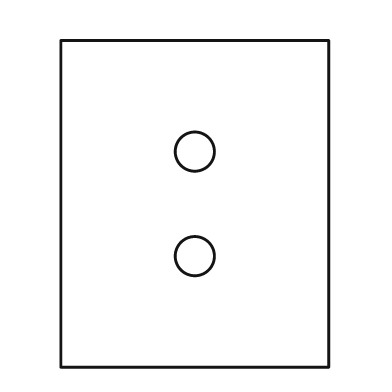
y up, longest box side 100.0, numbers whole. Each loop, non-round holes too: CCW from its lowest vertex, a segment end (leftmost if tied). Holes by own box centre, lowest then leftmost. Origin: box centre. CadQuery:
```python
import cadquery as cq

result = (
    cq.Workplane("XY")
    .moveTo(-41.0, -50.0)
    .lineTo(41.0, -50.0)
    .lineTo(41.0, 50.0)
    .lineTo(-41.0, 50.0)
    .close()
    .moveTo(0.0, -16.0)
    .circle(6.0)
    .moveTo(0.0, 16.0)
    .circle(6.0)
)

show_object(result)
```